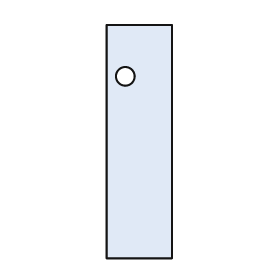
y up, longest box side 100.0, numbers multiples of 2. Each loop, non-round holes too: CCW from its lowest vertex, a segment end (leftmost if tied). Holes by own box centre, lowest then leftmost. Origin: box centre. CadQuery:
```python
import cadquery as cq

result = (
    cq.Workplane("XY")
    .moveTo(-14.0, -50.0)
    .lineTo(14.0, -50.0)
    .lineTo(14.0, 50.0)
    .lineTo(-14.0, 50.0)
    .close()
    .moveTo(-6.0, 28.0)
    .circle(4.0)
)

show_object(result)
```